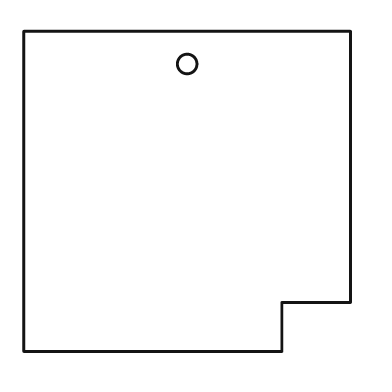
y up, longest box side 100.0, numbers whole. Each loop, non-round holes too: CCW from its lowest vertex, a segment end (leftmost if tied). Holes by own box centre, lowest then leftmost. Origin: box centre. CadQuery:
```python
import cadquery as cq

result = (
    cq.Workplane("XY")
    .moveTo(-50.0, -49.0)
    .lineTo(29.0, -49.0)
    .lineTo(29.0, -34.0)
    .lineTo(50.0, -34.0)
    .lineTo(50.0, 49.0)
    .lineTo(-50.0, 49.0)
    .close()
    .moveTo(0.0, 39.0)
    .circle(3.0)
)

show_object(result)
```